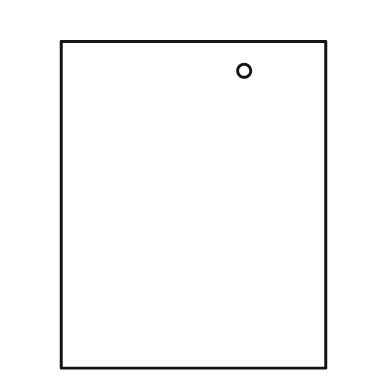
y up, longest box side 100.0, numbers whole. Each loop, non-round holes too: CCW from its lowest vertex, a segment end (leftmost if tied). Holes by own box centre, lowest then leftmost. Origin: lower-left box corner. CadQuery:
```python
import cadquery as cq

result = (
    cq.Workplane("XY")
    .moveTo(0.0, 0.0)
    .lineTo(81.0, 0.0)
    .lineTo(81.0, 100.0)
    .lineTo(0.0, 100.0)
    .close()
    .moveTo(56.0, 91.0)
    .circle(2.0)
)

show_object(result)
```